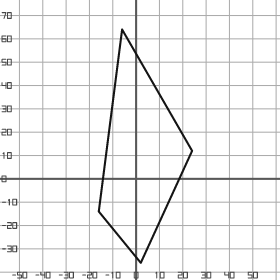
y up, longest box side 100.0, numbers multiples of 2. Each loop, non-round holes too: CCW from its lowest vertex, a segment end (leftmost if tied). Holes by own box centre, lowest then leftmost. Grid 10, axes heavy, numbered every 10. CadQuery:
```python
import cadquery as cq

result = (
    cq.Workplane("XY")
    .moveTo(2.0, -36.0)
    .lineTo(24.0, 12.0)
    .lineTo(-6.0, 64.0)
    .lineTo(-16.0, -14.0)
    .close()
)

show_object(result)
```